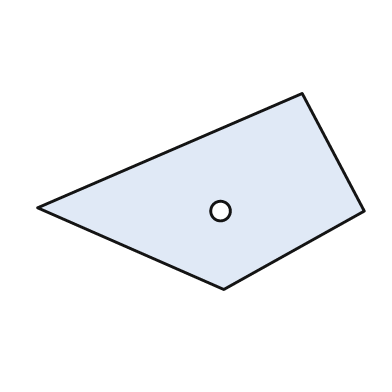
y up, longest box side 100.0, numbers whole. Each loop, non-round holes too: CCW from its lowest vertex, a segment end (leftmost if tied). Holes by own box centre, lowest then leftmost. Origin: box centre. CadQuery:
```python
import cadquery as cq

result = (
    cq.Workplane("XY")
    .moveTo(7.0, -30.0)
    .lineTo(50.0, -6.0)
    .lineTo(31.0, 30.0)
    .lineTo(-50.0, -5.0)
    .close()
    .moveTo(6.0, -6.0)
    .circle(3.0)
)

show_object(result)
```